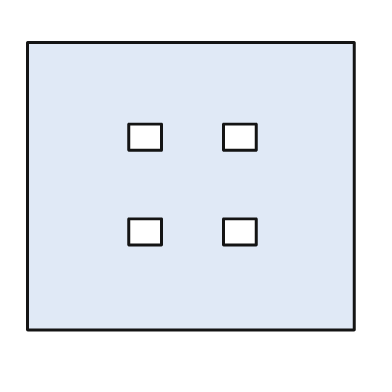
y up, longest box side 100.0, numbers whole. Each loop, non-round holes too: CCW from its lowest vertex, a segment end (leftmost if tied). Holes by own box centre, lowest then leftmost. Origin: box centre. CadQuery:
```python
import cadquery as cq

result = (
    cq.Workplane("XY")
    .moveTo(-50.0, -44.0)
    .lineTo(50.0, -44.0)
    .lineTo(50.0, 44.0)
    .lineTo(-50.0, 44.0)
    .close()
    .moveTo(-19.0, -18.0)
    .lineTo(-9.0, -18.0)
    .lineTo(-9.0, -10.0)
    .lineTo(-19.0, -10.0)
    .close()
    .moveTo(10.0, -18.0)
    .lineTo(20.0, -18.0)
    .lineTo(20.0, -10.0)
    .lineTo(10.0, -10.0)
    .close()
    .moveTo(-19.0, 11.0)
    .lineTo(-9.0, 11.0)
    .lineTo(-9.0, 19.0)
    .lineTo(-19.0, 19.0)
    .close()
    .moveTo(10.0, 11.0)
    .lineTo(20.0, 11.0)
    .lineTo(20.0, 19.0)
    .lineTo(10.0, 19.0)
    .close()
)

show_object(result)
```